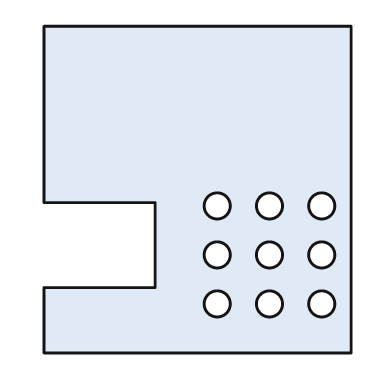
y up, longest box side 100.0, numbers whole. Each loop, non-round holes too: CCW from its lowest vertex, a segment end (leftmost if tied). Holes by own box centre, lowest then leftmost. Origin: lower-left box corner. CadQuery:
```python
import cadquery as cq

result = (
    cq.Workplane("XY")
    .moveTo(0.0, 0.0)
    .lineTo(94.0, 0.0)
    .lineTo(94.0, 100.0)
    .lineTo(0.0, 100.0)
    .lineTo(0.0, 46.0)
    .lineTo(34.0, 46.0)
    .lineTo(34.0, 20.0)
    .lineTo(0.0, 20.0)
    .close()
    .moveTo(53.0, 15.0)
    .circle(4.0)
    .moveTo(69.0, 15.0)
    .circle(4.0)
    .moveTo(85.0, 15.0)
    .circle(4.0)
    .moveTo(53.0, 30.0)
    .circle(4.0)
    .moveTo(69.0, 30.0)
    .circle(4.0)
    .moveTo(85.0, 30.0)
    .circle(4.0)
    .moveTo(53.0, 45.0)
    .circle(4.0)
    .moveTo(69.0, 45.0)
    .circle(4.0)
    .moveTo(85.0, 45.0)
    .circle(4.0)
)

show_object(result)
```